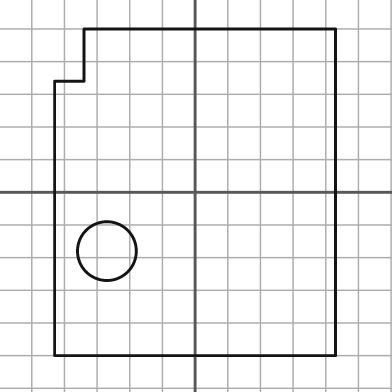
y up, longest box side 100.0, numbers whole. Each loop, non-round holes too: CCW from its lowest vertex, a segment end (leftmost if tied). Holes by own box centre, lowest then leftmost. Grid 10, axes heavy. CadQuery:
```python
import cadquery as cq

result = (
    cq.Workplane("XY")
    .moveTo(-43.0, -50.0)
    .lineTo(43.0, -50.0)
    .lineTo(43.0, 50.0)
    .lineTo(-34.0, 50.0)
    .lineTo(-34.0, 34.0)
    .lineTo(-43.0, 34.0)
    .close()
    .moveTo(-27.0, -18.0)
    .circle(9.0)
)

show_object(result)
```